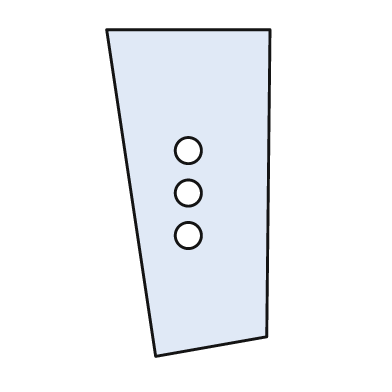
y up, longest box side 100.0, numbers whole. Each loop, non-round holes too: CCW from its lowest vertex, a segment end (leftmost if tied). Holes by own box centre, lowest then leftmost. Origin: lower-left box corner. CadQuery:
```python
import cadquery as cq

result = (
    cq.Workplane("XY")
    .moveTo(15.0, 0.0)
    .lineTo(49.0, 6.0)
    .lineTo(50.0, 100.0)
    .lineTo(0.0, 100.0)
    .close()
    .moveTo(25.0, 37.0)
    .circle(4.0)
    .moveTo(25.0, 50.0)
    .circle(4.0)
    .moveTo(25.0, 63.0)
    .circle(4.0)
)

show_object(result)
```